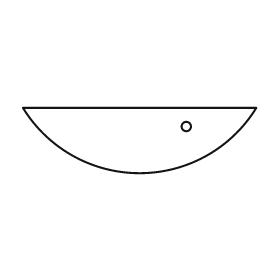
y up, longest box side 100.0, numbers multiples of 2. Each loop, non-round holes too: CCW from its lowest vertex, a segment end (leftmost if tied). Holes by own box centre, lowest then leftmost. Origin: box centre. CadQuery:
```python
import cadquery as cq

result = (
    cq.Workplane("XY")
    .moveTo(-50.0, 14.0)
    .threePointArc((0.0, -14.0), (50.0, 14.0))
    .close()
    .moveTo(20.0, 6.0)
    .circle(2.0)
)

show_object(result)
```